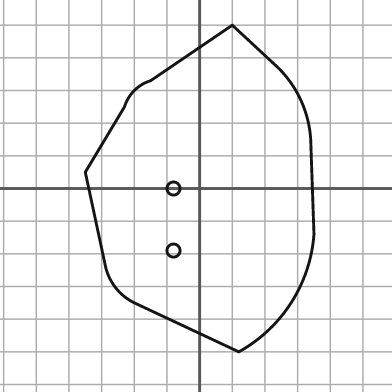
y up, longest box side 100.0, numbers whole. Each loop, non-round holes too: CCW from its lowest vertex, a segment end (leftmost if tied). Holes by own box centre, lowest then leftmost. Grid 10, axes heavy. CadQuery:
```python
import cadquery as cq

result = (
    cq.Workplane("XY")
    .moveTo(12.0, -50.0)
    .threePointArc((28.0, -35.0), (35.0, -14.0))
    .lineTo(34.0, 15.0)
    .threePointArc((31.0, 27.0), (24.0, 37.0))
    .lineTo(10.0, 50.0)
    .lineTo(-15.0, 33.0)
    .threePointArc((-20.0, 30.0), (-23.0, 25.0))
    .lineTo(-35.0, 5.0)
    .lineTo(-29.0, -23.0)
    .threePointArc((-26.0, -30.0), (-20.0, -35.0))
    .close()
    .moveTo(-8.0, -19.0)
    .circle(2.0)
    .moveTo(-8.0, 0.0)
    .circle(2.0)
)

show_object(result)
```